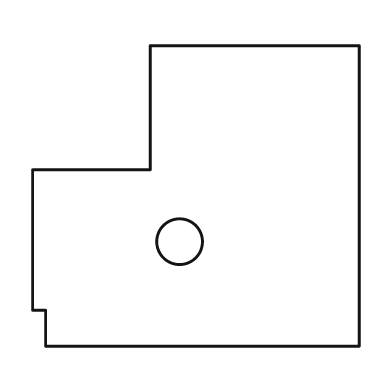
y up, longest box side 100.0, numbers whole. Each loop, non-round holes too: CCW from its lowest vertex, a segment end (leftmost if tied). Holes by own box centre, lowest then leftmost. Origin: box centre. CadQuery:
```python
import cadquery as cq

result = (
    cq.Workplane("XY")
    .moveTo(-46.0, -46.0)
    .lineTo(50.0, -46.0)
    .lineTo(50.0, 46.0)
    .lineTo(-14.0, 46.0)
    .lineTo(-14.0, 8.0)
    .lineTo(-50.0, 8.0)
    .lineTo(-50.0, -35.0)
    .lineTo(-46.0, -35.0)
    .close()
    .moveTo(-5.0, -14.0)
    .circle(7.0)
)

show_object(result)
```